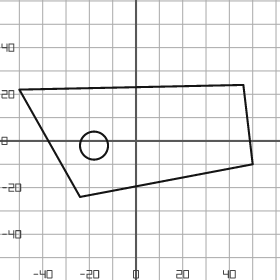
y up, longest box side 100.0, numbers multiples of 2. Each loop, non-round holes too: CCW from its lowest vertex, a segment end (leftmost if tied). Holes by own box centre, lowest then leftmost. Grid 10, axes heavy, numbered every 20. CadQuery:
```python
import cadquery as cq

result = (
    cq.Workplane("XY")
    .moveTo(-24.0, -24.0)
    .lineTo(50.0, -10.0)
    .lineTo(46.0, 24.0)
    .lineTo(-50.0, 22.0)
    .close()
    .moveTo(-18.0, -2.0)
    .circle(6.0)
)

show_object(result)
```